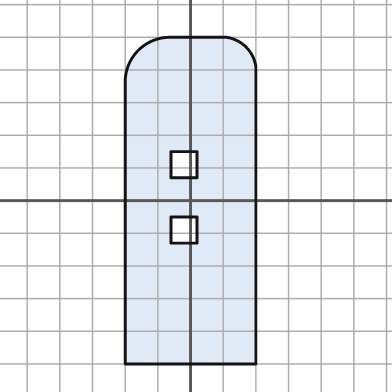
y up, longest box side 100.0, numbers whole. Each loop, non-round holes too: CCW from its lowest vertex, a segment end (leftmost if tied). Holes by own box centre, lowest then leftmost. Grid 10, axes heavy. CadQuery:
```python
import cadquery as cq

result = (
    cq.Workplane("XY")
    .moveTo(-20.0, -50.0)
    .lineTo(20.0, -50.0)
    .lineTo(20.0, 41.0)
    .threePointArc((17.0, 47.0), (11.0, 50.0))
    .lineTo(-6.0, 50.0)
    .threePointArc((-16.0, 46.0), (-20.0, 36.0))
    .close()
    .moveTo(-6.0, -13.0)
    .lineTo(2.0, -13.0)
    .lineTo(2.0, -5.0)
    .lineTo(-6.0, -5.0)
    .close()
    .moveTo(-6.0, 7.0)
    .lineTo(2.0, 7.0)
    .lineTo(2.0, 15.0)
    .lineTo(-6.0, 15.0)
    .close()
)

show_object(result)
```